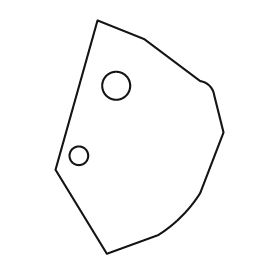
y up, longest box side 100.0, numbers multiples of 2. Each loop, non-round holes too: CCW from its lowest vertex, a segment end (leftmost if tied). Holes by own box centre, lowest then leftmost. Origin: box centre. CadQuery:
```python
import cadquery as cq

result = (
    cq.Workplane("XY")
    .moveTo(-14.0, -50.0)
    .lineTo(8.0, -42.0)
    .threePointArc((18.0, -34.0), (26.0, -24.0))
    .lineTo(36.0, 2.0)
    .lineTo(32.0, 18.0)
    .threePointArc((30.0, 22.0), (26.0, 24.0))
    .lineTo(2.0, 42.0)
    .lineTo(-18.0, 50.0)
    .lineTo(-36.0, -14.0)
    .close()
    .moveTo(-26.0, -8.0)
    .circle(4.0)
    .moveTo(-10.0, 22.0)
    .circle(6.0)
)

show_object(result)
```